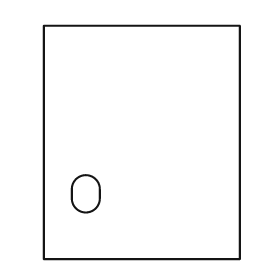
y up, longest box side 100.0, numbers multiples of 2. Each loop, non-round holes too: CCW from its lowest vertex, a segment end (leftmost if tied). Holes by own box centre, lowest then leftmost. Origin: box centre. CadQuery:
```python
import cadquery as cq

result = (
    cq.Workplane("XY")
    .moveTo(-42.0, -50.0)
    .lineTo(42.0, -50.0)
    .lineTo(42.0, 50.0)
    .lineTo(-42.0, 50.0)
    .close()
    .moveTo(-30.0, -24.0)
    .threePointArc((-24.0, -30.0), (-18.0, -24.0))
    .lineTo(-18.0, -20.0)
    .threePointArc((-24.0, -14.0), (-30.0, -20.0))
    .close()
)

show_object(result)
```